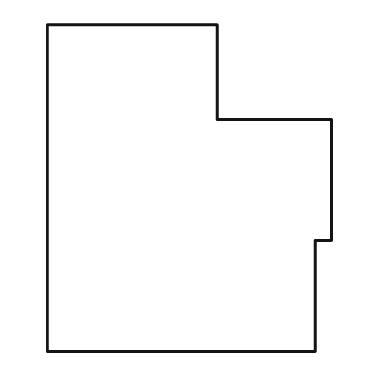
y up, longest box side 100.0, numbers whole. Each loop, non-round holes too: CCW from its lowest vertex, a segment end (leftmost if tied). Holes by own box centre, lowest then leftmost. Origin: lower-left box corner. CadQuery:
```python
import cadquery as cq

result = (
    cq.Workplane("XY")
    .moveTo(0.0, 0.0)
    .lineTo(82.0, 0.0)
    .lineTo(82.0, 34.0)
    .lineTo(87.0, 34.0)
    .lineTo(87.0, 71.0)
    .lineTo(52.0, 71.0)
    .lineTo(52.0, 100.0)
    .lineTo(0.0, 100.0)
    .close()
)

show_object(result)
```